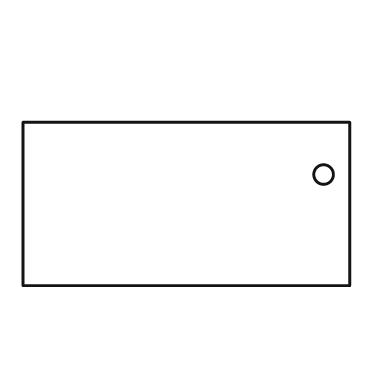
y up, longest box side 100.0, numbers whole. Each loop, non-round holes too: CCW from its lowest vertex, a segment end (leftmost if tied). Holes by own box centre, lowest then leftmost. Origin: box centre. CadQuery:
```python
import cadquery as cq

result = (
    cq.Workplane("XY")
    .moveTo(-50.0, -25.0)
    .lineTo(50.0, -25.0)
    .lineTo(50.0, 25.0)
    .lineTo(-50.0, 25.0)
    .close()
    .moveTo(42.0, 9.0)
    .circle(3.0)
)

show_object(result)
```